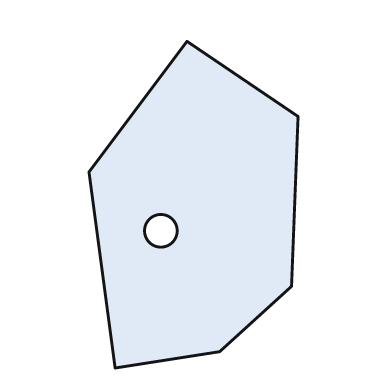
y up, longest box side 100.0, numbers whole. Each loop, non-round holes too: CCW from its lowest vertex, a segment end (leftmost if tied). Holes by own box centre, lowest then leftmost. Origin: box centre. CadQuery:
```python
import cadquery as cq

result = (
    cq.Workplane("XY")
    .moveTo(-24.0, -50.0)
    .lineTo(8.0, -45.0)
    .lineTo(30.0, -25.0)
    .lineTo(32.0, 27.0)
    .lineTo(-2.0, 50.0)
    .lineTo(-32.0, 10.0)
    .close()
    .moveTo(-10.0, -8.0)
    .circle(5.0)
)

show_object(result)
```